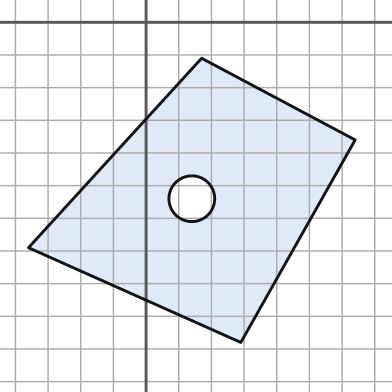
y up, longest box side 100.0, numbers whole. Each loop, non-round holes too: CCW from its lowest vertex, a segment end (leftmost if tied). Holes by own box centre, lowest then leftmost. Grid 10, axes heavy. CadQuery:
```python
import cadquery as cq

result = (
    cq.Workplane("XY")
    .moveTo(29.0, -98.0)
    .lineTo(64.0, -36.0)
    .lineTo(17.0, -11.0)
    .lineTo(-36.0, -69.0)
    .close()
    .moveTo(14.0, -54.0)
    .circle(7.0)
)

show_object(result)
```